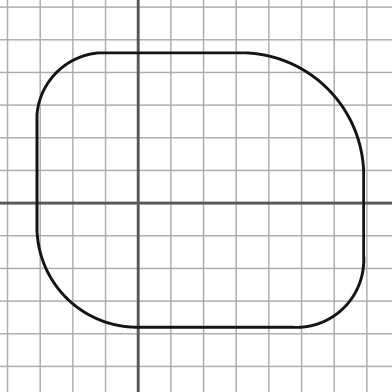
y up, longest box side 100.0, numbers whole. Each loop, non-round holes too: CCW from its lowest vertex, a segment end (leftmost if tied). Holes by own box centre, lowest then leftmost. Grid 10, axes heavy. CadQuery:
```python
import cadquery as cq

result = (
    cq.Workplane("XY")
    .moveTo(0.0, -38.0)
    .lineTo(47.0, -38.0)
    .threePointArc((63.0, -32.0), (69.0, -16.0))
    .lineTo(69.0, 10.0)
    .threePointArc((58.0, 35.0), (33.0, 46.0))
    .lineTo(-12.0, 46.0)
    .threePointArc((-25.0, 40.0), (-31.0, 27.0))
    .lineTo(-31.0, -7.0)
    .threePointArc((-22.0, -29.0), (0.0, -38.0))
    .close()
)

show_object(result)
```